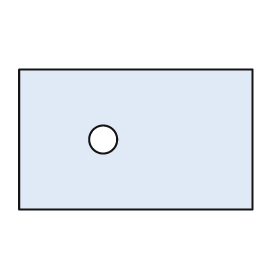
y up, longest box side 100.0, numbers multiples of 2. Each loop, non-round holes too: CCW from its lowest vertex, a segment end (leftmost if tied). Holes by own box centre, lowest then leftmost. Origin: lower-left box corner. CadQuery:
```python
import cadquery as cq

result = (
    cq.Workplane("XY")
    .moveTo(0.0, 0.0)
    .lineTo(100.0, 0.0)
    .lineTo(100.0, 60.0)
    .lineTo(0.0, 60.0)
    .close()
    .moveTo(36.0, 30.0)
    .circle(6.0)
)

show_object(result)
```